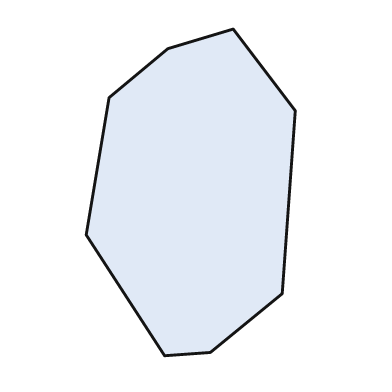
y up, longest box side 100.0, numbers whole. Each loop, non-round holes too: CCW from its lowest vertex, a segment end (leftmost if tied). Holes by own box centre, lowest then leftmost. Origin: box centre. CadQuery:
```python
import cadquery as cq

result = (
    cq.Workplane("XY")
    .moveTo(-8.0, -50.0)
    .lineTo(6.0, -49.0)
    .lineTo(28.0, -31.0)
    .lineTo(32.0, 25.0)
    .lineTo(13.0, 50.0)
    .lineTo(-7.0, 44.0)
    .lineTo(-25.0, 29.0)
    .lineTo(-32.0, -13.0)
    .close()
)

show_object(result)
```